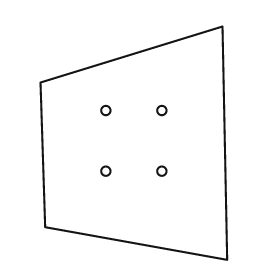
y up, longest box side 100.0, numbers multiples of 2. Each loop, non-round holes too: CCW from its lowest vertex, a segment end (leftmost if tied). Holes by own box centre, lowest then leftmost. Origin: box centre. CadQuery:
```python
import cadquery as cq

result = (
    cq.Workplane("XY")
    .moveTo(40.0, -50.0)
    .lineTo(38.0, 50.0)
    .lineTo(-40.0, 26.0)
    .lineTo(-38.0, -36.0)
    .close()
    .moveTo(-12.0, -12.0)
    .circle(2.0)
    .moveTo(12.0, -12.0)
    .circle(2.0)
    .moveTo(-12.0, 14.0)
    .circle(2.0)
    .moveTo(12.0, 14.0)
    .circle(2.0)
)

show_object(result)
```